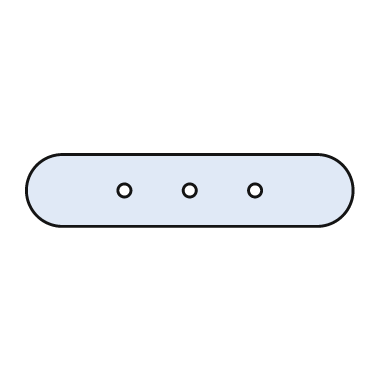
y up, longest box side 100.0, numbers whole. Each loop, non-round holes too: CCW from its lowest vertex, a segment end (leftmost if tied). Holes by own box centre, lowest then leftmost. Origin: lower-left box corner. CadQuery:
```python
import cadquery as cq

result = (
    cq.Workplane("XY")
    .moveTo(11.0, 0.0)
    .lineTo(89.0, 0.0)
    .threePointArc((100.0, 11.0), (89.0, 22.0))
    .lineTo(11.0, 22.0)
    .threePointArc((0.0, 11.0), (11.0, 0.0))
    .close()
    .moveTo(30.0, 11.0)
    .circle(2.0)
    .moveTo(50.0, 11.0)
    .circle(2.0)
    .moveTo(70.0, 11.0)
    .circle(2.0)
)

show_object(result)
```